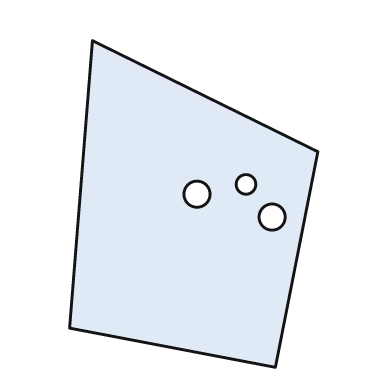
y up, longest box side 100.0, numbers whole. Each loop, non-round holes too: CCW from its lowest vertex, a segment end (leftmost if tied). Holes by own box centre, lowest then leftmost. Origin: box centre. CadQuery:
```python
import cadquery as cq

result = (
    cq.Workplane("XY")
    .moveTo(25.0, -50.0)
    .lineTo(38.0, 16.0)
    .lineTo(-31.0, 50.0)
    .lineTo(-38.0, -38.0)
    .close()
    .moveTo(24.0, -4.0)
    .circle(4.0)
    .moveTo(1.0, 3.0)
    .circle(4.0)
    .moveTo(16.0, 6.0)
    .circle(3.0)
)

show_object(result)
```